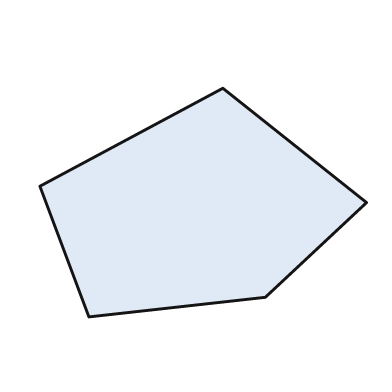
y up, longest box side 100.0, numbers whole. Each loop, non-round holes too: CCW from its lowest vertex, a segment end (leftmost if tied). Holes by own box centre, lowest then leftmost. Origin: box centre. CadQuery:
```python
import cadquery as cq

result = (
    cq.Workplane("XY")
    .moveTo(-35.0, -35.0)
    .lineTo(19.0, -29.0)
    .lineTo(50.0, 0.0)
    .lineTo(6.0, 35.0)
    .lineTo(-50.0, 5.0)
    .close()
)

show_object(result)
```